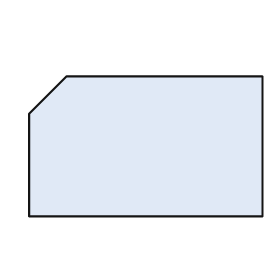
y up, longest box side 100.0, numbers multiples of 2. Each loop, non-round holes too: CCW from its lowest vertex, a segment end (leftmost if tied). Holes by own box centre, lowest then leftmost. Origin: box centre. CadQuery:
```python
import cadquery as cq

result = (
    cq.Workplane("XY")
    .moveTo(-50.0, -30.0)
    .lineTo(50.0, -30.0)
    .lineTo(50.0, 30.0)
    .lineTo(-34.0, 30.0)
    .lineTo(-50.0, 14.0)
    .close()
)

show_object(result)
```